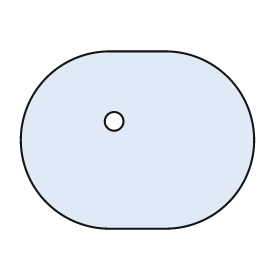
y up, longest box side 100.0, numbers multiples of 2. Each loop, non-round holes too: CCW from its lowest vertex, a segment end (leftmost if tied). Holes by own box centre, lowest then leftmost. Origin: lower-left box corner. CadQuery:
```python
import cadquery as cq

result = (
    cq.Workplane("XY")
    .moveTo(38.0, 0.0)
    .lineTo(62.0, 0.0)
    .threePointArc((100.0, 38.0), (62.0, 76.0))
    .lineTo(38.0, 76.0)
    .threePointArc((0.0, 38.0), (38.0, 0.0))
    .close()
    .moveTo(40.0, 46.0)
    .circle(4.0)
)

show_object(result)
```